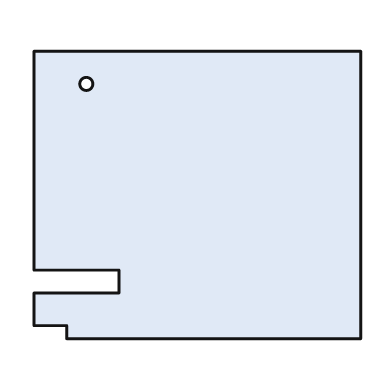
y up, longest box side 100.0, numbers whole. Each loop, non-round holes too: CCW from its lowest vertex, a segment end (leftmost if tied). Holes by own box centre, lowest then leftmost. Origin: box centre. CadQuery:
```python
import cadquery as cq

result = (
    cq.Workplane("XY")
    .moveTo(-40.0, -44.0)
    .lineTo(50.0, -44.0)
    .lineTo(50.0, 44.0)
    .lineTo(-50.0, 44.0)
    .lineTo(-50.0, -23.0)
    .lineTo(-24.0, -23.0)
    .lineTo(-24.0, -30.0)
    .lineTo(-50.0, -30.0)
    .lineTo(-50.0, -40.0)
    .lineTo(-40.0, -40.0)
    .close()
    .moveTo(-34.0, 34.0)
    .circle(2.0)
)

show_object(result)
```